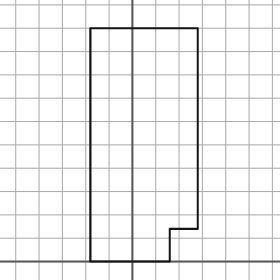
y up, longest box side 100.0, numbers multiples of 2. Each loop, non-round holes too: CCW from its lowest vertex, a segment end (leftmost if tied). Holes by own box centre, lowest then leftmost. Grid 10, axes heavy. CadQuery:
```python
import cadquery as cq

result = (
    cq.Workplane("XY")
    .moveTo(-18.0, 0.0)
    .lineTo(16.0, 0.0)
    .lineTo(16.0, 14.0)
    .lineTo(28.0, 14.0)
    .lineTo(28.0, 100.0)
    .lineTo(-18.0, 100.0)
    .close()
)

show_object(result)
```